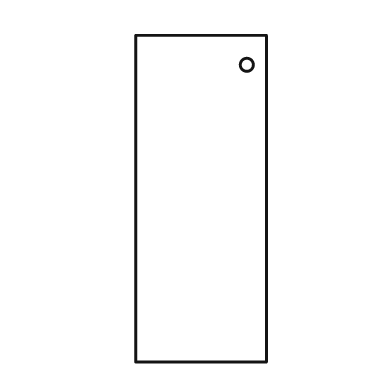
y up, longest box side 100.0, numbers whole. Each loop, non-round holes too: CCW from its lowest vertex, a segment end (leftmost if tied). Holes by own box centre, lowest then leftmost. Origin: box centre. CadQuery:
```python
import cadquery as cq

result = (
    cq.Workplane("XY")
    .moveTo(-20.0, -50.0)
    .lineTo(20.0, -50.0)
    .lineTo(20.0, 50.0)
    .lineTo(-20.0, 50.0)
    .close()
    .moveTo(14.0, 41.0)
    .circle(2.0)
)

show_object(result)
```